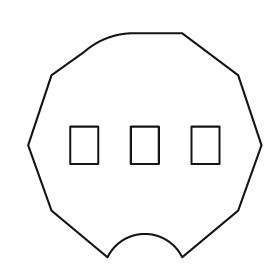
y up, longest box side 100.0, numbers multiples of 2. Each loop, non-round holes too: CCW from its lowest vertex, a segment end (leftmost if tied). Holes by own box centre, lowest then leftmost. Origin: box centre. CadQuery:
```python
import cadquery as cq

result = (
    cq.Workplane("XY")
    .moveTo(-16.0, -48.0)
    .threePointArc((0.0, -38.0), (16.0, -48.0))
    .lineTo(40.0, -28.0)
    .lineTo(50.0, 0.0)
    .lineTo(40.0, 30.0)
    .lineTo(16.0, 48.0)
    .lineTo(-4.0, 48.0)
    .threePointArc((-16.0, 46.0), (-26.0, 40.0))
    .lineTo(-40.0, 30.0)
    .lineTo(-50.0, 0.0)
    .lineTo(-40.0, -28.0)
    .close()
    .moveTo(-32.0, -8.0)
    .lineTo(-20.0, -8.0)
    .lineTo(-20.0, 8.0)
    .lineTo(-32.0, 8.0)
    .close()
    .moveTo(-6.0, -8.0)
    .lineTo(6.0, -8.0)
    .lineTo(6.0, 8.0)
    .lineTo(-6.0, 8.0)
    .close()
    .moveTo(20.0, -8.0)
    .lineTo(32.0, -8.0)
    .lineTo(32.0, 8.0)
    .lineTo(20.0, 8.0)
    .close()
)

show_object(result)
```